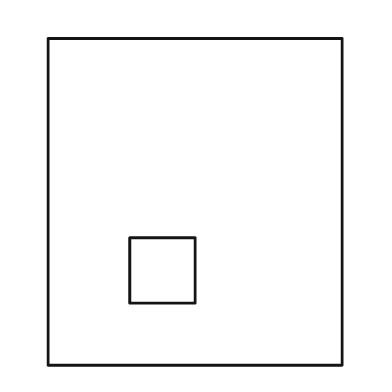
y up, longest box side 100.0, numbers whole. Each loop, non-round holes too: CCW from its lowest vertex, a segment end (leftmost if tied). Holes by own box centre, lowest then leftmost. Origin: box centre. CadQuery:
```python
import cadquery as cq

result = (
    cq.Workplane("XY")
    .moveTo(-45.0, -50.0)
    .lineTo(45.0, -50.0)
    .lineTo(45.0, 50.0)
    .lineTo(-45.0, 50.0)
    .close()
    .moveTo(-20.0, -31.0)
    .lineTo(0.0, -31.0)
    .lineTo(0.0, -11.0)
    .lineTo(-20.0, -11.0)
    .close()
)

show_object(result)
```